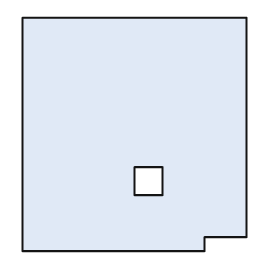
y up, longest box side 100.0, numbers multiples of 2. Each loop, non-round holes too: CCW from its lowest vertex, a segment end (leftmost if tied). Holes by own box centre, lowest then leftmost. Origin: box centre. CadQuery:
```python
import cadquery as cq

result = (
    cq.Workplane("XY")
    .moveTo(-48.0, -50.0)
    .lineTo(30.0, -50.0)
    .lineTo(30.0, -44.0)
    .lineTo(48.0, -44.0)
    .lineTo(48.0, 50.0)
    .lineTo(-48.0, 50.0)
    .close()
    .moveTo(0.0, -26.0)
    .lineTo(12.0, -26.0)
    .lineTo(12.0, -14.0)
    .lineTo(0.0, -14.0)
    .close()
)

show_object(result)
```